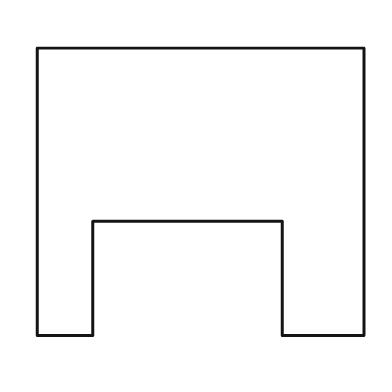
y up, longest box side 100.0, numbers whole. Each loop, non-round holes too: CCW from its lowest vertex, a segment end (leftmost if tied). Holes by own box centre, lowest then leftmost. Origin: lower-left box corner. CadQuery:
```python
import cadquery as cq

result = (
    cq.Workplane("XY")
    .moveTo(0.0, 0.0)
    .lineTo(17.0, 0.0)
    .lineTo(17.0, 35.0)
    .lineTo(75.0, 35.0)
    .lineTo(75.0, 0.0)
    .lineTo(100.0, 0.0)
    .lineTo(100.0, 88.0)
    .lineTo(0.0, 88.0)
    .close()
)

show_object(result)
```